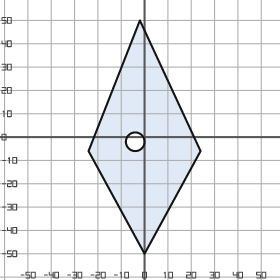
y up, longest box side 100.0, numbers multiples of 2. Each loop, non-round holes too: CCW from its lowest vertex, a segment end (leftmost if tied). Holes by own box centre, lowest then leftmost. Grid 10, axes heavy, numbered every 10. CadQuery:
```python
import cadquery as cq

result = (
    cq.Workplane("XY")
    .moveTo(0.0, -50.0)
    .lineTo(24.0, -6.0)
    .lineTo(-2.0, 50.0)
    .lineTo(-24.0, -6.0)
    .close()
    .moveTo(-4.0, -2.0)
    .circle(4.0)
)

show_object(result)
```